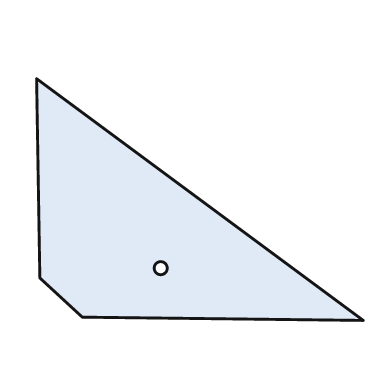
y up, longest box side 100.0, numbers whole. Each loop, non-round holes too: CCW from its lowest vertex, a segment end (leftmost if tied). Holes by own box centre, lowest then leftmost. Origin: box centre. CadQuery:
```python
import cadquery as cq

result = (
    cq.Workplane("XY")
    .moveTo(50.0, -37.0)
    .lineTo(-50.0, 37.0)
    .lineTo(-49.0, -24.0)
    .lineTo(-36.0, -36.0)
    .close()
    .moveTo(-12.0, -21.0)
    .circle(2.0)
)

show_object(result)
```